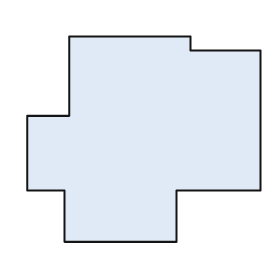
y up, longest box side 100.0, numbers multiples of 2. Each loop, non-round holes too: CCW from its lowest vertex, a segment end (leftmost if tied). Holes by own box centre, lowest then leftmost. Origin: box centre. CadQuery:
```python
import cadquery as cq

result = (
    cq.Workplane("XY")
    .moveTo(-34.0, -44.0)
    .lineTo(14.0, -44.0)
    .lineTo(14.0, -22.0)
    .lineTo(50.0, -22.0)
    .lineTo(50.0, 38.0)
    .lineTo(20.0, 38.0)
    .lineTo(20.0, 44.0)
    .lineTo(-32.0, 44.0)
    .lineTo(-32.0, 10.0)
    .lineTo(-50.0, 10.0)
    .lineTo(-50.0, -22.0)
    .lineTo(-34.0, -22.0)
    .close()
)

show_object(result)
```